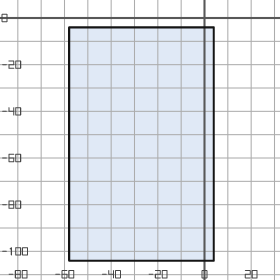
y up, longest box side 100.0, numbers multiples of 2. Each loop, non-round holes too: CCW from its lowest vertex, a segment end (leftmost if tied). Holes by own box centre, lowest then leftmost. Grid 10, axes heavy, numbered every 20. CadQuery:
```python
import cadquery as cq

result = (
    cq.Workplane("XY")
    .moveTo(-58.0, -104.0)
    .lineTo(4.0, -104.0)
    .lineTo(4.0, -4.0)
    .lineTo(-58.0, -4.0)
    .close()
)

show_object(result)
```